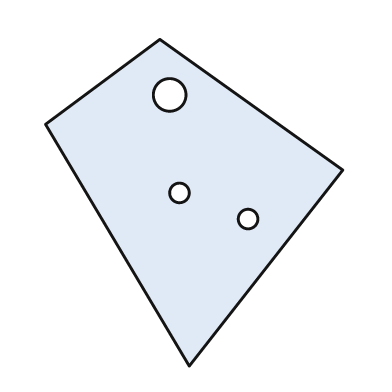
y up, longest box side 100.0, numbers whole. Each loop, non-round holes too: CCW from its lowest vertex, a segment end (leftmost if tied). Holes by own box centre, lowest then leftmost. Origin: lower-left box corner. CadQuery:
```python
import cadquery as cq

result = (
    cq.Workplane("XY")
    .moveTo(44.0, 0.0)
    .lineTo(91.0, 60.0)
    .lineTo(35.0, 100.0)
    .lineTo(0.0, 74.0)
    .close()
    .moveTo(62.0, 45.0)
    .circle(3.0)
    .moveTo(41.0, 53.0)
    .circle(3.0)
    .moveTo(38.0, 83.0)
    .circle(5.0)
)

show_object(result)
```